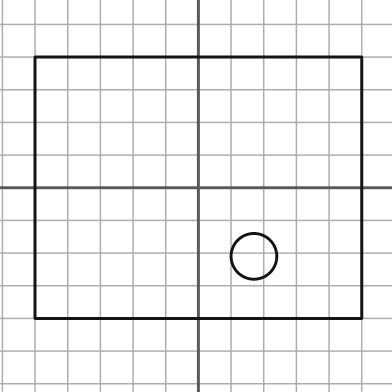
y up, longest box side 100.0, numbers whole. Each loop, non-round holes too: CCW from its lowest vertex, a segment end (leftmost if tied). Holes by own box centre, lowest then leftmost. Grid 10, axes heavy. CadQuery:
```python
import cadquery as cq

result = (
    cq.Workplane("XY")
    .moveTo(-50.0, -40.0)
    .lineTo(50.0, -40.0)
    .lineTo(50.0, 40.0)
    .lineTo(-50.0, 40.0)
    .close()
    .moveTo(17.0, -21.0)
    .circle(7.0)
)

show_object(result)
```